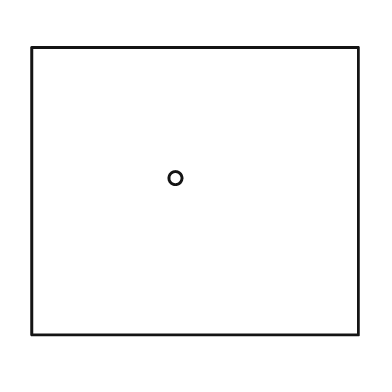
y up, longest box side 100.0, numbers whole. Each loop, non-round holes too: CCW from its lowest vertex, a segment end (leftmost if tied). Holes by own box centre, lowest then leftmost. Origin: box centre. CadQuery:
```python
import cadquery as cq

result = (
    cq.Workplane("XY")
    .moveTo(-50.0, -44.0)
    .lineTo(50.0, -44.0)
    .lineTo(50.0, 44.0)
    .lineTo(-50.0, 44.0)
    .close()
    .moveTo(-6.0, 4.0)
    .circle(2.0)
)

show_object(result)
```